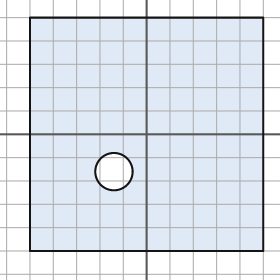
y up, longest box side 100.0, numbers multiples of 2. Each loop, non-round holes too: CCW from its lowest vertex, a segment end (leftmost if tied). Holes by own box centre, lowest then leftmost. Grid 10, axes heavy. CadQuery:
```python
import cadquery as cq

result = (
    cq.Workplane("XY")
    .moveTo(-50.0, -50.0)
    .lineTo(50.0, -50.0)
    .lineTo(50.0, 50.0)
    .lineTo(-50.0, 50.0)
    .close()
    .moveTo(-14.0, -16.0)
    .circle(8.0)
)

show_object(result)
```